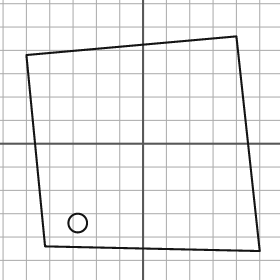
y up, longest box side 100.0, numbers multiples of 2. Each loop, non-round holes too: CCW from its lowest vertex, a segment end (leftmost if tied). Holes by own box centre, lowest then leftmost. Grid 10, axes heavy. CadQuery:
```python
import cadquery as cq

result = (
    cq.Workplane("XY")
    .moveTo(50.0, -46.0)
    .lineTo(40.0, 46.0)
    .lineTo(-50.0, 38.0)
    .lineTo(-42.0, -44.0)
    .close()
    .moveTo(-28.0, -34.0)
    .circle(4.0)
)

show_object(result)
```